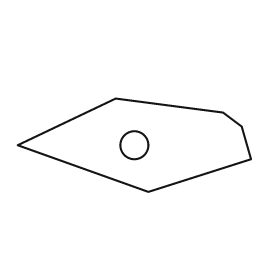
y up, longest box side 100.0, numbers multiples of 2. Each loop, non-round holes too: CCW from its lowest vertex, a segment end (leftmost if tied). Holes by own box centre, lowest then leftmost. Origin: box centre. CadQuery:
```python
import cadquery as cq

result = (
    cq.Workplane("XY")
    .moveTo(6.0, -20.0)
    .lineTo(50.0, -6.0)
    .lineTo(46.0, 8.0)
    .lineTo(38.0, 14.0)
    .lineTo(-8.0, 20.0)
    .lineTo(-50.0, 0.0)
    .close()
    .moveTo(0.0, 0.0)
    .circle(6.0)
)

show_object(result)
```